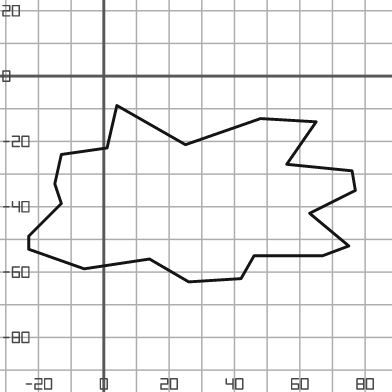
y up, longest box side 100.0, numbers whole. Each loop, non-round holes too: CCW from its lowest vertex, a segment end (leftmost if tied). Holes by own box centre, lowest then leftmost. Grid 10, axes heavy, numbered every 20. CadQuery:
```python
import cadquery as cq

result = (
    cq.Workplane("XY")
    .moveTo(26.0, -63.0)
    .lineTo(42.0, -62.0)
    .lineTo(46.0, -55.0)
    .lineTo(67.0, -55.0)
    .lineTo(75.0, -52.0)
    .lineTo(63.0, -42.0)
    .lineTo(77.0, -35.0)
    .lineTo(76.0, -29.0)
    .lineTo(56.0, -27.0)
    .lineTo(65.0, -14.0)
    .lineTo(48.0, -13.0)
    .lineTo(25.0, -21.0)
    .lineTo(4.0, -9.0)
    .lineTo(1.0, -22.0)
    .lineTo(-13.0, -24.0)
    .lineTo(-15.0, -33.0)
    .lineTo(-13.0, -39.0)
    .lineTo(-23.0, -49.0)
    .lineTo(-23.0, -53.0)
    .lineTo(-6.0, -59.0)
    .lineTo(14.0, -56.0)
    .close()
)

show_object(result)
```